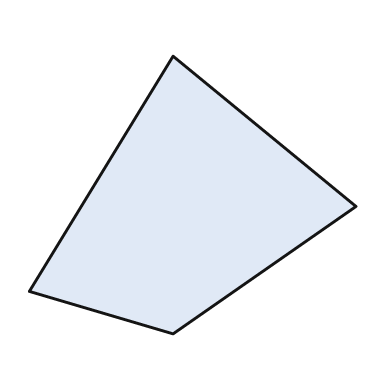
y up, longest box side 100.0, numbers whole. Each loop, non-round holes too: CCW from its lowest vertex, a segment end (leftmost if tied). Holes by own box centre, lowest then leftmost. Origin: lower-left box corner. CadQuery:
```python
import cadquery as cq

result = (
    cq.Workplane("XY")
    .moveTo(44.0, 0.0)
    .lineTo(100.0, 39.0)
    .lineTo(44.0, 85.0)
    .lineTo(0.0, 13.0)
    .close()
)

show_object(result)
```